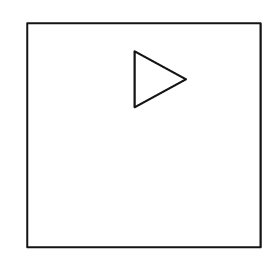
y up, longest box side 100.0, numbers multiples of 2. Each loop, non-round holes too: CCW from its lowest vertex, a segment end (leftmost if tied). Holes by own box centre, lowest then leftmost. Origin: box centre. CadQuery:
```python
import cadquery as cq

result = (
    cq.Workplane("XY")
    .moveTo(-50.0, -48.0)
    .lineTo(50.0, -48.0)
    .lineTo(50.0, 48.0)
    .lineTo(-50.0, 48.0)
    .close()
    .moveTo(-4.0, 12.0)
    .lineTo(18.0, 24.0)
    .lineTo(-4.0, 36.0)
    .close()
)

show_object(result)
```